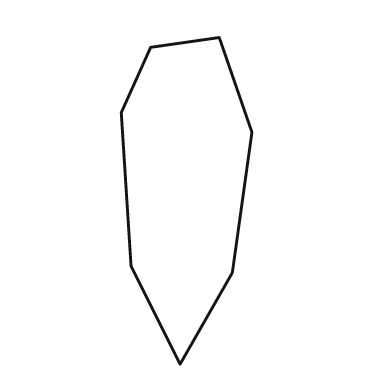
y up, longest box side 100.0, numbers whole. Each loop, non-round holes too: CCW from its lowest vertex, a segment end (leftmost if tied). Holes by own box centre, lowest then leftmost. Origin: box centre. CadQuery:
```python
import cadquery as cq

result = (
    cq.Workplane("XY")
    .moveTo(-2.0, -50.0)
    .lineTo(14.0, -22.0)
    .lineTo(20.0, 21.0)
    .lineTo(10.0, 50.0)
    .lineTo(-11.0, 47.0)
    .lineTo(-20.0, 27.0)
    .lineTo(-17.0, -20.0)
    .close()
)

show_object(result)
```